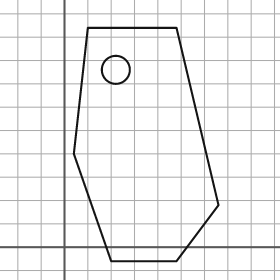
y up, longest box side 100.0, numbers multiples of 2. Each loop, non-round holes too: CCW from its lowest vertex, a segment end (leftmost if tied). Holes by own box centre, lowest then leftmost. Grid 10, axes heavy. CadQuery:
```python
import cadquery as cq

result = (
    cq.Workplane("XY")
    .moveTo(20.0, -6.0)
    .lineTo(48.0, -6.0)
    .lineTo(66.0, 18.0)
    .lineTo(48.0, 94.0)
    .lineTo(10.0, 94.0)
    .lineTo(4.0, 40.0)
    .close()
    .moveTo(22.0, 76.0)
    .circle(6.0)
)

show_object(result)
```